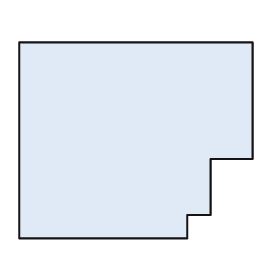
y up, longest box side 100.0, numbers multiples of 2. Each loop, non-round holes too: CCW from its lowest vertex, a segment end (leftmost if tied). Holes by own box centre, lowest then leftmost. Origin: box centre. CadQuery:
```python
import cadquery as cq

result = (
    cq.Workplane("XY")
    .moveTo(-50.0, -42.0)
    .lineTo(22.0, -42.0)
    .lineTo(22.0, -32.0)
    .lineTo(32.0, -32.0)
    .lineTo(32.0, -8.0)
    .lineTo(50.0, -8.0)
    .lineTo(50.0, 42.0)
    .lineTo(-50.0, 42.0)
    .close()
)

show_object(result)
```